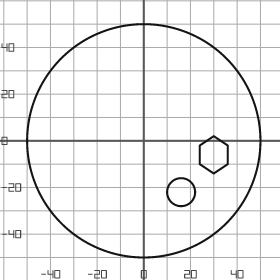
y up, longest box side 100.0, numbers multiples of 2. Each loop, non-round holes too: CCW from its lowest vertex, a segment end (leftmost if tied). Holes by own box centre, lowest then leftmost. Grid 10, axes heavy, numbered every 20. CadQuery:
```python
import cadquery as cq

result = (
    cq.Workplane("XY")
    .moveTo(0.0, 0.0)
    .circle(50.0)
    .moveTo(16.0, -22.0)
    .circle(6.0)
    .moveTo(30.0, -14.0)
    .lineTo(36.0, -10.0)
    .lineTo(36.0, -2.0)
    .lineTo(30.0, 2.0)
    .lineTo(24.0, -2.0)
    .lineTo(24.0, -10.0)
    .close()
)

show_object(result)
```